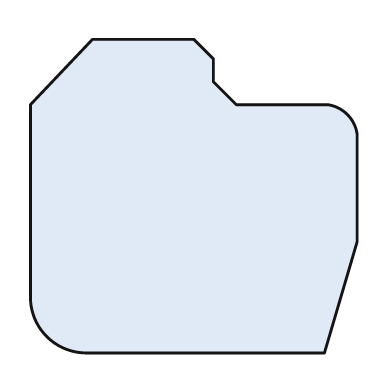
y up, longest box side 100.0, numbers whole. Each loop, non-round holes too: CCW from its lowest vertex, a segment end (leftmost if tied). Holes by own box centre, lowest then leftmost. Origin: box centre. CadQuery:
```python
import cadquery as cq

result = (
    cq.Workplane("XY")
    .moveTo(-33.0, -48.0)
    .lineTo(40.0, -48.0)
    .lineTo(50.0, -14.0)
    .lineTo(50.0, 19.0)
    .threePointArc((47.0, 25.0), (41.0, 28.0))
    .lineTo(13.0, 28.0)
    .lineTo(6.0, 35.0)
    .lineTo(6.0, 42.0)
    .lineTo(0.0, 48.0)
    .lineTo(-31.0, 48.0)
    .lineTo(-50.0, 28.0)
    .lineTo(-50.0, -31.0)
    .threePointArc((-45.0, -43.0), (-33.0, -48.0))
    .close()
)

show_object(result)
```